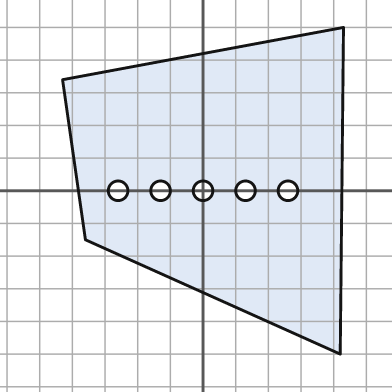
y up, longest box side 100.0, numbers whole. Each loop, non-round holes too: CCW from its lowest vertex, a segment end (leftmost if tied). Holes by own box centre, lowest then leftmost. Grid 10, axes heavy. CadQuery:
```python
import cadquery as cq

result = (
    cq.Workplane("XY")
    .moveTo(42.0, -50.0)
    .lineTo(43.0, 50.0)
    .lineTo(-43.0, 34.0)
    .lineTo(-36.0, -15.0)
    .close()
    .moveTo(-26.0, 0.0)
    .circle(3.0)
    .moveTo(-13.0, 0.0)
    .circle(3.0)
    .moveTo(0.0, 0.0)
    .circle(3.0)
    .moveTo(13.0, 0.0)
    .circle(3.0)
    .moveTo(26.0, 0.0)
    .circle(3.0)
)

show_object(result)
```